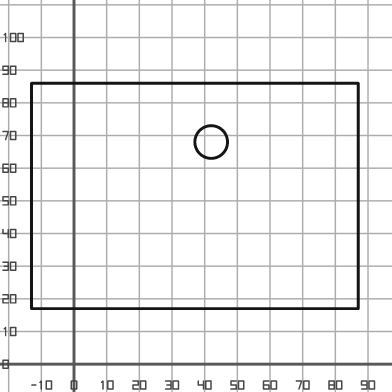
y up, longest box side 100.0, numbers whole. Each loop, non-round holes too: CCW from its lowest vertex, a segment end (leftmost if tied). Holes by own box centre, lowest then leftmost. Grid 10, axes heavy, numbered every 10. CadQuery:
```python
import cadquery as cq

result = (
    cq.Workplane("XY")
    .moveTo(-13.0, 17.0)
    .lineTo(87.0, 17.0)
    .lineTo(87.0, 86.0)
    .lineTo(-13.0, 86.0)
    .close()
    .moveTo(42.0, 68.0)
    .circle(5.0)
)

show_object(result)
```